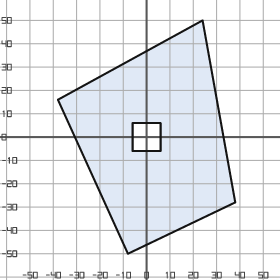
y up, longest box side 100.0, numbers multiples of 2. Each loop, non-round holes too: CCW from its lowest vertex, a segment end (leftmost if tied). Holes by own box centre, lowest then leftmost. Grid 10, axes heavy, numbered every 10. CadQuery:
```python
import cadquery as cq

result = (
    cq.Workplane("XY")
    .moveTo(-8.0, -50.0)
    .lineTo(38.0, -28.0)
    .lineTo(24.0, 50.0)
    .lineTo(-38.0, 16.0)
    .close()
    .moveTo(-6.0, -6.0)
    .lineTo(6.0, -6.0)
    .lineTo(6.0, 6.0)
    .lineTo(-6.0, 6.0)
    .close()
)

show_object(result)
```